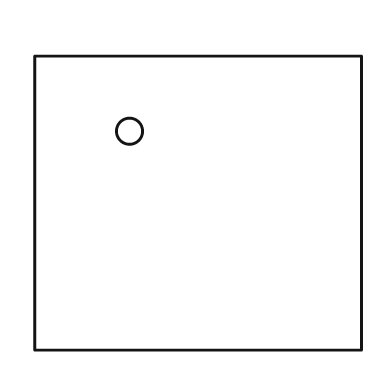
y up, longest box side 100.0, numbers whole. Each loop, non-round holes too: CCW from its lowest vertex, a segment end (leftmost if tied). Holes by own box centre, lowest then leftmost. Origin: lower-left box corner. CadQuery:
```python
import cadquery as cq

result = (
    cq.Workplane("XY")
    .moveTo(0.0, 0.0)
    .lineTo(100.0, 0.0)
    .lineTo(100.0, 90.0)
    .lineTo(0.0, 90.0)
    .close()
    .moveTo(29.0, 67.0)
    .circle(4.0)
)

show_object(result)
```